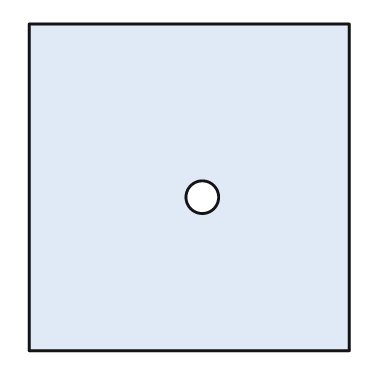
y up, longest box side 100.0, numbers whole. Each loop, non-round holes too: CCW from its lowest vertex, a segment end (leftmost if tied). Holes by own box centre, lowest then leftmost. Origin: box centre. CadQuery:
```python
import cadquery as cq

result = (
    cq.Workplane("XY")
    .moveTo(-49.0, -50.0)
    .lineTo(49.0, -50.0)
    .lineTo(49.0, 50.0)
    .lineTo(-49.0, 50.0)
    .close()
    .moveTo(4.0, -3.0)
    .circle(5.0)
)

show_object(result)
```